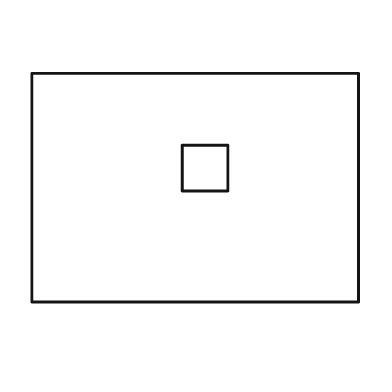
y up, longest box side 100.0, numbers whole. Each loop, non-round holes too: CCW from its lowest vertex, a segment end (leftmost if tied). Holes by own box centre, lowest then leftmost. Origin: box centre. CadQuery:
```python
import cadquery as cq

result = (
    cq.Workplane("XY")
    .moveTo(-50.0, -35.0)
    .lineTo(50.0, -35.0)
    .lineTo(50.0, 35.0)
    .lineTo(-50.0, 35.0)
    .close()
    .moveTo(-4.0, -1.0)
    .lineTo(10.0, -1.0)
    .lineTo(10.0, 13.0)
    .lineTo(-4.0, 13.0)
    .close()
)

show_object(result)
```